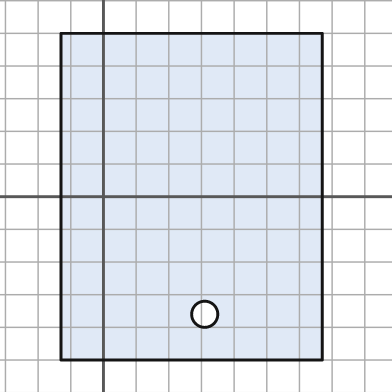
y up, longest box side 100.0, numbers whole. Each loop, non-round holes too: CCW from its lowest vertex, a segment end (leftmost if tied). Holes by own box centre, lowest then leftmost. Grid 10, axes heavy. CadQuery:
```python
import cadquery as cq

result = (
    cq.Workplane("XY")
    .moveTo(-13.0, -50.0)
    .lineTo(67.0, -50.0)
    .lineTo(67.0, 50.0)
    .lineTo(-13.0, 50.0)
    .close()
    .moveTo(31.0, -36.0)
    .circle(4.0)
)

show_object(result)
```